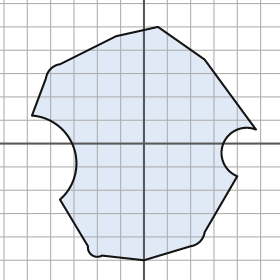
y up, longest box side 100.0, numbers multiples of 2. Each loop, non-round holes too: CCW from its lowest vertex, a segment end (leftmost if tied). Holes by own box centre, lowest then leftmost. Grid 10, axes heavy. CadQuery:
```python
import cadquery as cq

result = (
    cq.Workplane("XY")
    .moveTo(0.0, -50.0)
    .lineTo(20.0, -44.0)
    .threePointArc((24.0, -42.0), (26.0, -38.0))
    .lineTo(40.0, -14.0)
    .threePointArc((34.0, 0.0), (48.0, 6.0))
    .lineTo(26.0, 36.0)
    .lineTo(6.0, 50.0)
    .lineTo(-12.0, 46.0)
    .lineTo(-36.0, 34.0)
    .threePointArc((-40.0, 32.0), (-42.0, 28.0))
    .lineTo(-48.0, 12.0)
    .threePointArc((-30.0, -2.0), (-36.0, -24.0))
    .lineTo(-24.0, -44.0)
    .threePointArc((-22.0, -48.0), (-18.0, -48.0))
    .close()
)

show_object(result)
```